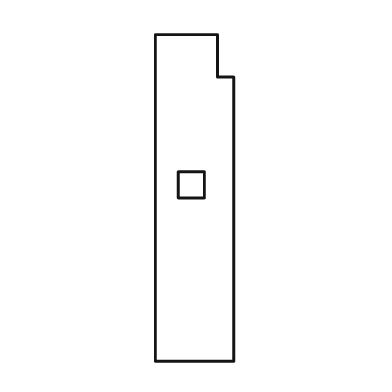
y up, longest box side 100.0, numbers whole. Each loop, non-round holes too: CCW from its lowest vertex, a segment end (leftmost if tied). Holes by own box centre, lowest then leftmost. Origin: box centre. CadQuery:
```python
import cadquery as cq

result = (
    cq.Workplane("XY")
    .moveTo(-12.0, -50.0)
    .lineTo(12.0, -50.0)
    .lineTo(12.0, 37.0)
    .lineTo(7.0, 37.0)
    .lineTo(7.0, 50.0)
    .lineTo(-12.0, 50.0)
    .close()
    .moveTo(-5.0, 0.0)
    .lineTo(3.0, 0.0)
    .lineTo(3.0, 8.0)
    .lineTo(-5.0, 8.0)
    .close()
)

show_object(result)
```